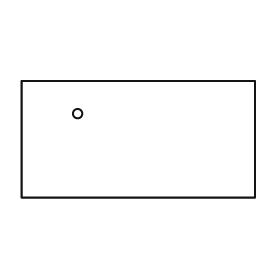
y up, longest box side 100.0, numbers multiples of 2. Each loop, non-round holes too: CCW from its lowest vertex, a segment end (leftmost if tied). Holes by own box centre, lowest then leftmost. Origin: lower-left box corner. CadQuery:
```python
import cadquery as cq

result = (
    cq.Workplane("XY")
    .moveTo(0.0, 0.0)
    .lineTo(100.0, 0.0)
    .lineTo(100.0, 50.0)
    .lineTo(0.0, 50.0)
    .close()
    .moveTo(24.0, 36.0)
    .circle(2.0)
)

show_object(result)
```